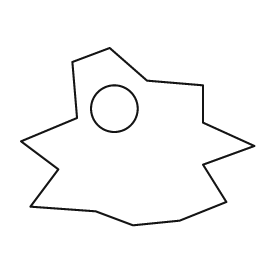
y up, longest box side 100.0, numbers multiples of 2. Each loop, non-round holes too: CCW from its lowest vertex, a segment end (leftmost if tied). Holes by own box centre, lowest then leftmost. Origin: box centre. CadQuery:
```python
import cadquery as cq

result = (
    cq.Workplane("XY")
    .moveTo(-2.0, -38.0)
    .lineTo(18.0, -36.0)
    .lineTo(38.0, -28.0)
    .lineTo(28.0, -12.0)
    .lineTo(50.0, -4.0)
    .lineTo(28.0, 6.0)
    .lineTo(28.0, 22.0)
    .lineTo(4.0, 24.0)
    .lineTo(-12.0, 38.0)
    .lineTo(-28.0, 32.0)
    .lineTo(-26.0, 8.0)
    .lineTo(-50.0, -2.0)
    .lineTo(-34.0, -14.0)
    .lineTo(-46.0, -30.0)
    .lineTo(-18.0, -32.0)
    .close()
    .moveTo(-10.0, 12.0)
    .circle(10.0)
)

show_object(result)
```